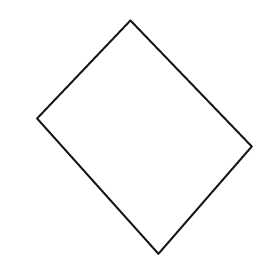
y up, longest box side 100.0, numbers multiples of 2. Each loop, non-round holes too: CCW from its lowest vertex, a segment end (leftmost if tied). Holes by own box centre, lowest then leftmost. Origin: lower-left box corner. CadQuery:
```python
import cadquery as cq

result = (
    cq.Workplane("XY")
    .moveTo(52.0, 0.0)
    .lineTo(92.0, 46.0)
    .lineTo(40.0, 100.0)
    .lineTo(0.0, 58.0)
    .close()
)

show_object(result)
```